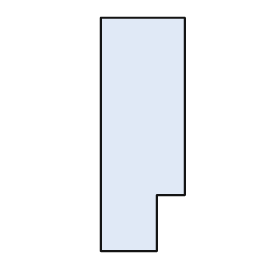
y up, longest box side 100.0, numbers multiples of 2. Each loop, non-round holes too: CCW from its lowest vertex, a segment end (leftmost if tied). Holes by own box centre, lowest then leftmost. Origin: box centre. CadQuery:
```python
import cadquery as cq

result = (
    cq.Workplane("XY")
    .moveTo(-18.0, -50.0)
    .lineTo(6.0, -50.0)
    .lineTo(6.0, -26.0)
    .lineTo(18.0, -26.0)
    .lineTo(18.0, 50.0)
    .lineTo(-18.0, 50.0)
    .close()
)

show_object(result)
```